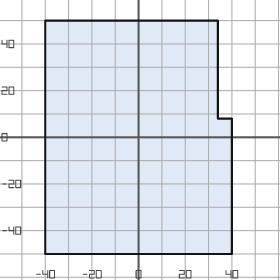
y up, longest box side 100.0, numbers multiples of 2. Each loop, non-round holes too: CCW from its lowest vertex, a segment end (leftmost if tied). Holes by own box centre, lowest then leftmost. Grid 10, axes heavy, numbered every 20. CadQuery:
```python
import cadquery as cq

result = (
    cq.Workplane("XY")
    .moveTo(-40.0, -50.0)
    .lineTo(40.0, -50.0)
    .lineTo(40.0, 8.0)
    .lineTo(34.0, 8.0)
    .lineTo(34.0, 50.0)
    .lineTo(-40.0, 50.0)
    .close()
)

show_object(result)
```